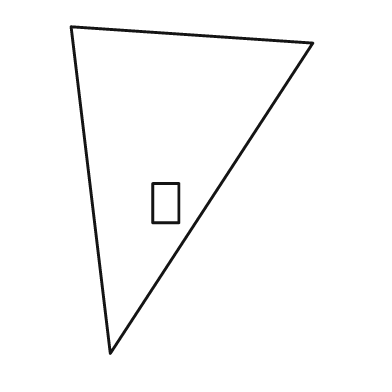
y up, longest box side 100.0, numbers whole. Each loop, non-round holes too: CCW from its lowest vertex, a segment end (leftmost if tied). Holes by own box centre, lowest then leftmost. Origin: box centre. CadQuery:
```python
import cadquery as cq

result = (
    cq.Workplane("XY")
    .moveTo(-25.0, -50.0)
    .lineTo(37.0, 45.0)
    .lineTo(-37.0, 50.0)
    .close()
    .moveTo(-12.0, -10.0)
    .lineTo(-4.0, -10.0)
    .lineTo(-4.0, 2.0)
    .lineTo(-12.0, 2.0)
    .close()
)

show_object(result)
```